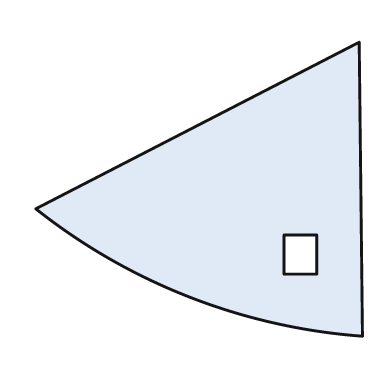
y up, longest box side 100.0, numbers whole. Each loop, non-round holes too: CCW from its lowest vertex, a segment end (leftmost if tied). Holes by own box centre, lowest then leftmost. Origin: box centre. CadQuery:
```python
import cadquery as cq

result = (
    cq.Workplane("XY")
    .moveTo(50.0, -45.0)
    .lineTo(49.0, 45.0)
    .lineTo(-50.0, -6.0)
    .threePointArc((-3.0, -33.0), (50.0, -45.0))
    .close()
    .moveTo(26.0, -26.0)
    .lineTo(36.0, -26.0)
    .lineTo(36.0, -14.0)
    .lineTo(26.0, -14.0)
    .close()
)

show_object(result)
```